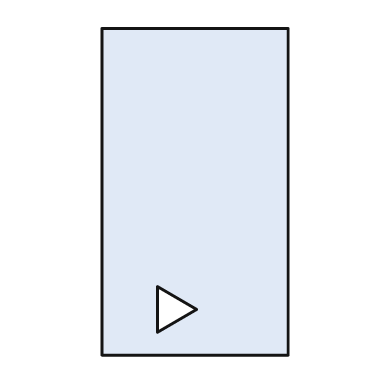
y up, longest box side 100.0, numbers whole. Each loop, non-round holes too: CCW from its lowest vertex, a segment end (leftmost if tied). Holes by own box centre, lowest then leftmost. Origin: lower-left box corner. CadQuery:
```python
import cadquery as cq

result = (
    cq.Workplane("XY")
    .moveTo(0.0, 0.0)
    .lineTo(57.0, 0.0)
    .lineTo(57.0, 100.0)
    .lineTo(0.0, 100.0)
    .close()
    .moveTo(17.0, 7.0)
    .lineTo(29.0, 14.0)
    .lineTo(17.0, 21.0)
    .close()
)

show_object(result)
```